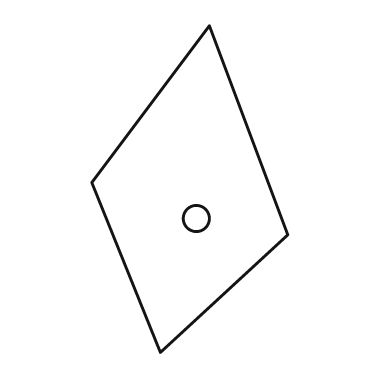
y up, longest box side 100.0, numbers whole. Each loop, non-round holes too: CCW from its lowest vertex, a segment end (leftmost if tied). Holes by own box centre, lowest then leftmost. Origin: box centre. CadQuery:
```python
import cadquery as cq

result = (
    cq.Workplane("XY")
    .moveTo(-9.0, -50.0)
    .lineTo(30.0, -14.0)
    .lineTo(6.0, 50.0)
    .lineTo(-30.0, 2.0)
    .close()
    .moveTo(2.0, -9.0)
    .circle(4.0)
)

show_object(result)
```